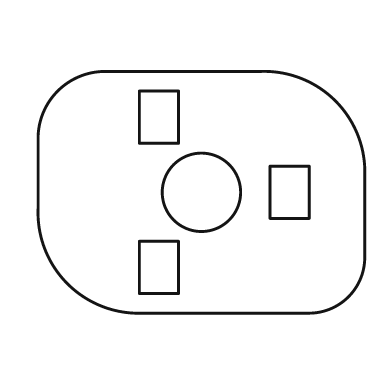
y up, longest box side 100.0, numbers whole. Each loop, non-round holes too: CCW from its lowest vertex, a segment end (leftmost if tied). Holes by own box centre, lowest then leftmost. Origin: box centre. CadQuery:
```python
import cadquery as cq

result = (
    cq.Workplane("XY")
    .moveTo(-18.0, -37.0)
    .lineTo(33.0, -37.0)
    .threePointArc((45.0, -32.0), (50.0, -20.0))
    .lineTo(50.0, 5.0)
    .threePointArc((41.0, 28.0), (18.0, 37.0))
    .lineTo(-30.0, 37.0)
    .threePointArc((-44.0, 31.0), (-50.0, 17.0))
    .lineTo(-50.0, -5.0)
    .threePointArc((-41.0, -28.0), (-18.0, -37.0))
    .close()
    .moveTo(-19.0, -31.0)
    .lineTo(-7.0, -31.0)
    .lineTo(-7.0, -15.0)
    .lineTo(-19.0, -15.0)
    .close()
    .moveTo(0.0, 0.0)
    .circle(12.0)
    .moveTo(21.0, -8.0)
    .lineTo(33.0, -8.0)
    .lineTo(33.0, 8.0)
    .lineTo(21.0, 8.0)
    .close()
    .moveTo(-19.0, 15.0)
    .lineTo(-7.0, 15.0)
    .lineTo(-7.0, 31.0)
    .lineTo(-19.0, 31.0)
    .close()
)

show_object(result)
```